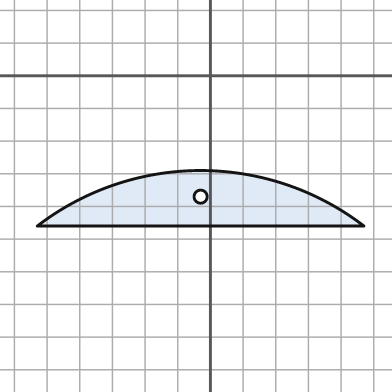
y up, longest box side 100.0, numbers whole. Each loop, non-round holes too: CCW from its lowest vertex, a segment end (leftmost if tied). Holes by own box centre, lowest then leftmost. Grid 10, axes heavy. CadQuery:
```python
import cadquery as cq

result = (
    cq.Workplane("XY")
    .moveTo(-53.0, -46.0)
    .lineTo(47.0, -46.0)
    .threePointArc((-3.0, -29.0), (-53.0, -46.0))
    .close()
    .moveTo(-3.0, -37.0)
    .circle(2.0)
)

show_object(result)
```